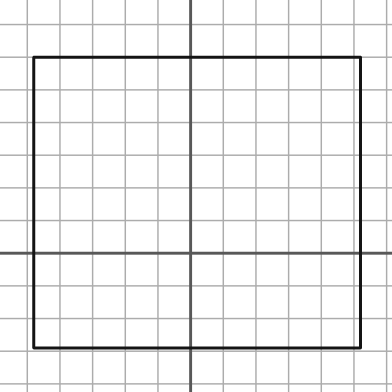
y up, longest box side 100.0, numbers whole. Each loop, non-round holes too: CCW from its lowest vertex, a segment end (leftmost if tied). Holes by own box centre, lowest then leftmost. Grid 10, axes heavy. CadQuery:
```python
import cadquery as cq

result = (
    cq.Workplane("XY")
    .moveTo(-48.0, -29.0)
    .lineTo(52.0, -29.0)
    .lineTo(52.0, 60.0)
    .lineTo(-48.0, 60.0)
    .close()
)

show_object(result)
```